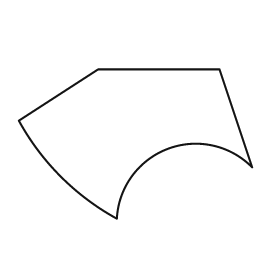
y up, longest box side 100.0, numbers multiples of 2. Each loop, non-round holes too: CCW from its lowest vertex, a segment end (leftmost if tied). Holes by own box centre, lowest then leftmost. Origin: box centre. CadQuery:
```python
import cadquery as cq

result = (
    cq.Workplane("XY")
    .moveTo(-8.0, -32.0)
    .threePointArc((14.0, -2.0), (50.0, -10.0))
    .lineTo(36.0, 32.0)
    .lineTo(-16.0, 32.0)
    .lineTo(-50.0, 10.0)
    .threePointArc((-32.0, -14.0), (-8.0, -32.0))
    .close()
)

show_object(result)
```